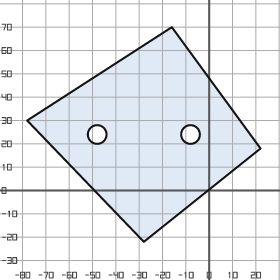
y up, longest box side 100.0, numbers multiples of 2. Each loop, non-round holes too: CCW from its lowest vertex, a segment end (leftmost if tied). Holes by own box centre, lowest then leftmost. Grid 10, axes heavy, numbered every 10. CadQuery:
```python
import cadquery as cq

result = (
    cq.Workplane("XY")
    .moveTo(-28.0, -22.0)
    .lineTo(22.0, 18.0)
    .lineTo(-16.0, 70.0)
    .lineTo(-78.0, 30.0)
    .close()
    .moveTo(-48.0, 24.0)
    .circle(4.0)
    .moveTo(-8.0, 24.0)
    .circle(4.0)
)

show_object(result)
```